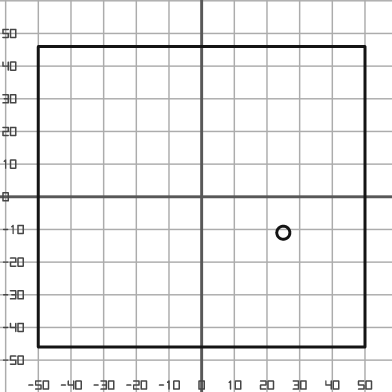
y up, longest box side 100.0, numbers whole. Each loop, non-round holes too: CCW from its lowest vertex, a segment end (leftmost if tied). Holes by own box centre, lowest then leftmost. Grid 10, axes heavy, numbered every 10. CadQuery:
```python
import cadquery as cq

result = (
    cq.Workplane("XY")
    .moveTo(-50.0, -46.0)
    .lineTo(50.0, -46.0)
    .lineTo(50.0, 46.0)
    .lineTo(-50.0, 46.0)
    .close()
    .moveTo(25.0, -11.0)
    .circle(2.0)
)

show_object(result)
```